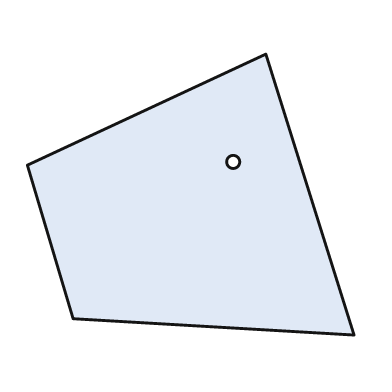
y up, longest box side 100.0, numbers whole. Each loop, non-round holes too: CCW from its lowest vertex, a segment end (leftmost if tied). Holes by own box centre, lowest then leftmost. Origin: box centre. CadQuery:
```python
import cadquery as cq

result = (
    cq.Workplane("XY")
    .moveTo(50.0, -43.0)
    .lineTo(23.0, 43.0)
    .lineTo(-50.0, 9.0)
    .lineTo(-36.0, -38.0)
    .close()
    .moveTo(13.0, 10.0)
    .circle(2.0)
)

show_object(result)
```